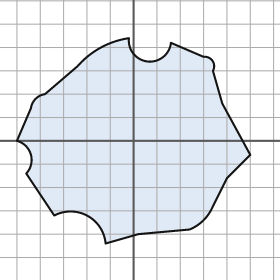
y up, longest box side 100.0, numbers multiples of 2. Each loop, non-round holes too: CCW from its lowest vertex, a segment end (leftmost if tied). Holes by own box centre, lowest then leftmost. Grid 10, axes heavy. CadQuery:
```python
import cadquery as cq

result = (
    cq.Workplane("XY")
    .moveTo(-12.0, -44.0)
    .lineTo(2.0, -40.0)
    .lineTo(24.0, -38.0)
    .threePointArc((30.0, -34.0), (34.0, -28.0))
    .lineTo(40.0, -16.0)
    .lineTo(50.0, -6.0)
    .lineTo(38.0, 16.0)
    .lineTo(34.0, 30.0)
    .threePointArc((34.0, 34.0), (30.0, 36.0))
    .lineTo(16.0, 42.0)
    .threePointArc((6.0, 34.0), (-2.0, 44.0))
    .threePointArc((-14.0, 40.0), (-24.0, 32.0))
    .lineTo(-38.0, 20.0)
    .threePointArc((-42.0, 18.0), (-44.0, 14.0))
    .lineTo(-50.0, 0.0)
    .threePointArc((-44.0, -6.0), (-46.0, -14.0))
    .lineTo(-34.0, -32.0)
    .threePointArc((-20.0, -32.0), (-12.0, -44.0))
    .close()
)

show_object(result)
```